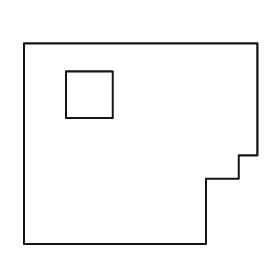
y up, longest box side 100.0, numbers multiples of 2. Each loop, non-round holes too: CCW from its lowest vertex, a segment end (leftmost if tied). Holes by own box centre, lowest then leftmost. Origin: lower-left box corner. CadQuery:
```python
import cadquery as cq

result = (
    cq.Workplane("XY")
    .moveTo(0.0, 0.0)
    .lineTo(78.0, 0.0)
    .lineTo(78.0, 28.0)
    .lineTo(92.0, 28.0)
    .lineTo(92.0, 38.0)
    .lineTo(100.0, 38.0)
    .lineTo(100.0, 86.0)
    .lineTo(0.0, 86.0)
    .close()
    .moveTo(18.0, 54.0)
    .lineTo(38.0, 54.0)
    .lineTo(38.0, 74.0)
    .lineTo(18.0, 74.0)
    .close()
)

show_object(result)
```